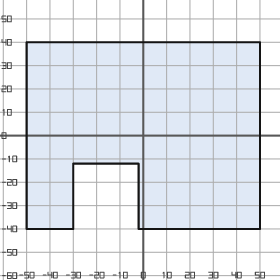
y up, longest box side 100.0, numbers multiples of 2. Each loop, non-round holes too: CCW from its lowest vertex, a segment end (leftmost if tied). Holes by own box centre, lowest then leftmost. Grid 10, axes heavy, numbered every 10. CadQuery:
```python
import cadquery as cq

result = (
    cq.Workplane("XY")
    .moveTo(-50.0, -40.0)
    .lineTo(-30.0, -40.0)
    .lineTo(-30.0, -12.0)
    .lineTo(-2.0, -12.0)
    .lineTo(-2.0, -40.0)
    .lineTo(50.0, -40.0)
    .lineTo(50.0, 40.0)
    .lineTo(-50.0, 40.0)
    .close()
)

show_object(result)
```